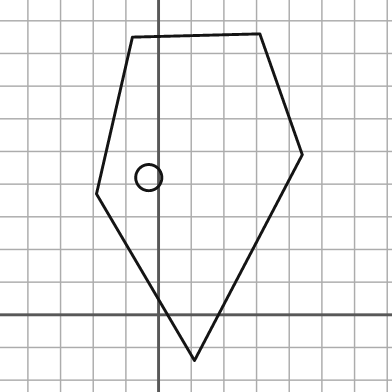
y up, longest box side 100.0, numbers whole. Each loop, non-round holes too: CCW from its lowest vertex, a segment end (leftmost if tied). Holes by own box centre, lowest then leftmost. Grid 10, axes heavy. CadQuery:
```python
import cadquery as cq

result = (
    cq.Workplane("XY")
    .moveTo(11.0, -14.0)
    .lineTo(44.0, 49.0)
    .lineTo(31.0, 86.0)
    .lineTo(-8.0, 85.0)
    .lineTo(-19.0, 37.0)
    .close()
    .moveTo(-3.0, 42.0)
    .circle(4.0)
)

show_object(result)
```